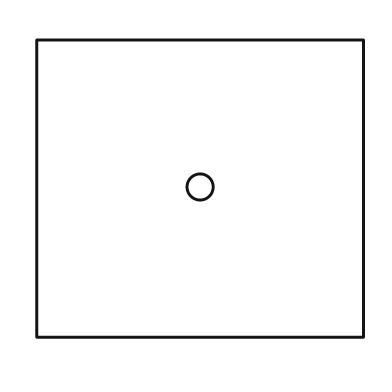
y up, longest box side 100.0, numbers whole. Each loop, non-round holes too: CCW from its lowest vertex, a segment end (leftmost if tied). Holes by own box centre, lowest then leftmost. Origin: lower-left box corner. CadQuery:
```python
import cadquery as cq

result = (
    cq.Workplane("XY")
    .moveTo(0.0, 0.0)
    .lineTo(100.0, 0.0)
    .lineTo(100.0, 91.0)
    .lineTo(0.0, 91.0)
    .close()
    .moveTo(50.0, 46.0)
    .circle(4.0)
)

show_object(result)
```